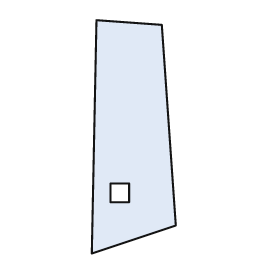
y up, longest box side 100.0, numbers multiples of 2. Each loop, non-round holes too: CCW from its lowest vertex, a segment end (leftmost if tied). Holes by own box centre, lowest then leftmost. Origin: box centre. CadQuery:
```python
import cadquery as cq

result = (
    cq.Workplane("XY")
    .moveTo(-18.0, -50.0)
    .lineTo(18.0, -38.0)
    .lineTo(12.0, 48.0)
    .lineTo(-16.0, 50.0)
    .close()
    .moveTo(-10.0, -28.0)
    .lineTo(-2.0, -28.0)
    .lineTo(-2.0, -20.0)
    .lineTo(-10.0, -20.0)
    .close()
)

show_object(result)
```